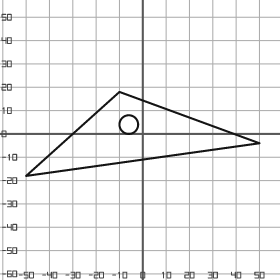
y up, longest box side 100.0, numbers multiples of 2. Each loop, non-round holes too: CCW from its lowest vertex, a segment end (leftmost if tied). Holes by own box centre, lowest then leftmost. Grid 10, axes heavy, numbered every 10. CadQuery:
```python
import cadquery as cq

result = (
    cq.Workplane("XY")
    .moveTo(-50.0, -18.0)
    .lineTo(50.0, -4.0)
    .lineTo(-10.0, 18.0)
    .close()
    .moveTo(-6.0, 4.0)
    .circle(4.0)
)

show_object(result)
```